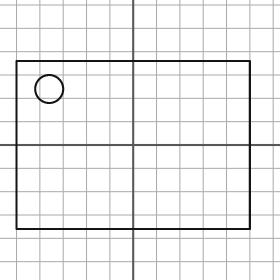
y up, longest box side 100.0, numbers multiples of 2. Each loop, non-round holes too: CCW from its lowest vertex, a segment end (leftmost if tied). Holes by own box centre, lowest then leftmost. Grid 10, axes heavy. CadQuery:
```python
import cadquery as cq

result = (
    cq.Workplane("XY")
    .moveTo(-50.0, -36.0)
    .lineTo(50.0, -36.0)
    .lineTo(50.0, 36.0)
    .lineTo(-50.0, 36.0)
    .close()
    .moveTo(-36.0, 24.0)
    .circle(6.0)
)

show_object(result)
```